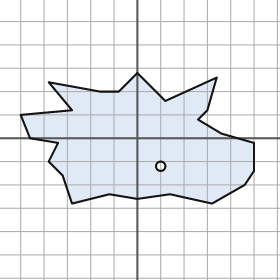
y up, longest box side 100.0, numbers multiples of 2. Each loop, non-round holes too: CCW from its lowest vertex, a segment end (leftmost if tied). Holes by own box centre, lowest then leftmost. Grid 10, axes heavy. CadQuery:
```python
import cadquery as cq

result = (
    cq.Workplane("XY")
    .moveTo(-28.0, -28.0)
    .lineTo(-12.0, -24.0)
    .lineTo(0.0, -26.0)
    .lineTo(14.0, -24.0)
    .lineTo(32.0, -28.0)
    .lineTo(46.0, -20.0)
    .lineTo(50.0, -14.0)
    .lineTo(50.0, -2.0)
    .lineTo(36.0, 2.0)
    .lineTo(26.0, 8.0)
    .lineTo(30.0, 12.0)
    .lineTo(34.0, 26.0)
    .lineTo(12.0, 16.0)
    .lineTo(0.0, 28.0)
    .lineTo(-8.0, 20.0)
    .lineTo(-16.0, 20.0)
    .lineTo(-38.0, 24.0)
    .lineTo(-28.0, 12.0)
    .lineTo(-50.0, 10.0)
    .lineTo(-46.0, 0.0)
    .lineTo(-34.0, -2.0)
    .lineTo(-38.0, -10.0)
    .lineTo(-32.0, -16.0)
    .close()
    .moveTo(10.0, -12.0)
    .circle(2.0)
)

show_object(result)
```